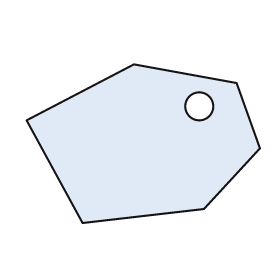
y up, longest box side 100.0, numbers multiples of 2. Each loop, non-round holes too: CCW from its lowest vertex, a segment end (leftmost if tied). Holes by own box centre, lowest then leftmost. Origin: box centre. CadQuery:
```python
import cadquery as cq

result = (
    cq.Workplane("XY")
    .moveTo(-26.0, -34.0)
    .lineTo(26.0, -28.0)
    .lineTo(50.0, -2.0)
    .lineTo(40.0, 26.0)
    .lineTo(-4.0, 34.0)
    .lineTo(-50.0, 10.0)
    .close()
    .moveTo(24.0, 16.0)
    .circle(6.0)
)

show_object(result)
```